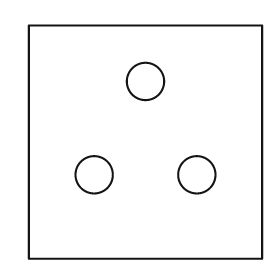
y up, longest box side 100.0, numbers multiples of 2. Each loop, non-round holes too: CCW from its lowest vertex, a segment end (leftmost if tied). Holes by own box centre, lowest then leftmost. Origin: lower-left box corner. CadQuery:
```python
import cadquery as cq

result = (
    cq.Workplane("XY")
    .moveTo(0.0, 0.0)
    .lineTo(100.0, 0.0)
    .lineTo(100.0, 100.0)
    .lineTo(0.0, 100.0)
    .close()
    .moveTo(28.0, 36.0)
    .circle(8.0)
    .moveTo(72.0, 36.0)
    .circle(8.0)
    .moveTo(50.0, 76.0)
    .circle(8.0)
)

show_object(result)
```